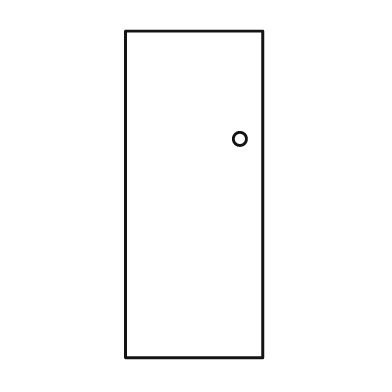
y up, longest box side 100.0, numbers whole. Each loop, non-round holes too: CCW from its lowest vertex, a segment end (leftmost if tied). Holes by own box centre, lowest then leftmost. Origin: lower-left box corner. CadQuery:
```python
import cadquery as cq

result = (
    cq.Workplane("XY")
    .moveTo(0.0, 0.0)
    .lineTo(42.0, 0.0)
    .lineTo(42.0, 100.0)
    .lineTo(0.0, 100.0)
    .close()
    .moveTo(35.0, 67.0)
    .circle(2.0)
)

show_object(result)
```